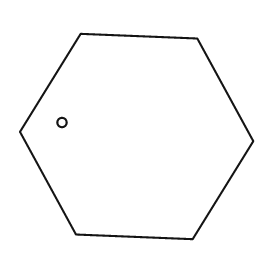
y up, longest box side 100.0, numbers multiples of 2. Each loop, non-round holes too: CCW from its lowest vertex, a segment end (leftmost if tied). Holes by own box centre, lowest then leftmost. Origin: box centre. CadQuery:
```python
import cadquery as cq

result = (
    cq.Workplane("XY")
    .moveTo(24.0, -44.0)
    .lineTo(50.0, -2.0)
    .lineTo(26.0, 42.0)
    .lineTo(-24.0, 44.0)
    .lineTo(-50.0, 2.0)
    .lineTo(-26.0, -42.0)
    .close()
    .moveTo(-32.0, 6.0)
    .circle(2.0)
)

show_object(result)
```